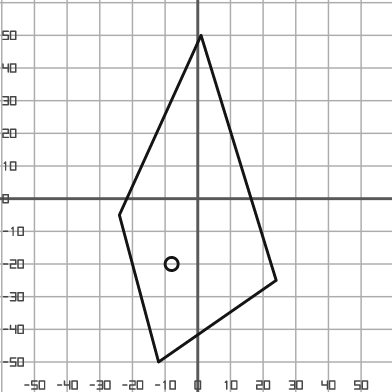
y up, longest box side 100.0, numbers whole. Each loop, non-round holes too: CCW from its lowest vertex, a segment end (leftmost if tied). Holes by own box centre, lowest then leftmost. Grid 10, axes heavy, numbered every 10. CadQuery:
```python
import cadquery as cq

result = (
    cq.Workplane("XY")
    .moveTo(-12.0, -50.0)
    .lineTo(24.0, -25.0)
    .lineTo(1.0, 50.0)
    .lineTo(-24.0, -5.0)
    .close()
    .moveTo(-8.0, -20.0)
    .circle(2.0)
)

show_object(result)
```